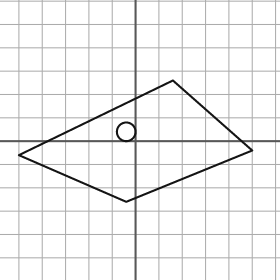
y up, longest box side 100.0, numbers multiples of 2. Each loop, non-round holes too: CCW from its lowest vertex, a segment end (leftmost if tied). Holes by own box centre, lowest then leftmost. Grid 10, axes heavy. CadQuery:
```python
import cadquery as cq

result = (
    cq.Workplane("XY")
    .moveTo(-4.0, -26.0)
    .lineTo(50.0, -4.0)
    .lineTo(16.0, 26.0)
    .lineTo(-50.0, -6.0)
    .close()
    .moveTo(-4.0, 4.0)
    .circle(4.0)
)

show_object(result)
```